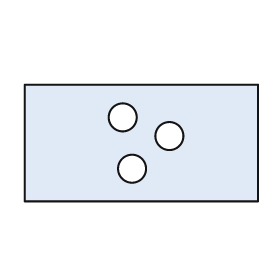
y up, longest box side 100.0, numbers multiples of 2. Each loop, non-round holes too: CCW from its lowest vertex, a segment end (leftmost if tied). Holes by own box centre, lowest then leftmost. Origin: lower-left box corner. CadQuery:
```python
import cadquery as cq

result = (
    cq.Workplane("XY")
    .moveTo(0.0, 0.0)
    .lineTo(100.0, 0.0)
    .lineTo(100.0, 50.0)
    .lineTo(0.0, 50.0)
    .close()
    .moveTo(46.0, 14.0)
    .circle(6.0)
    .moveTo(62.0, 28.0)
    .circle(6.0)
    .moveTo(42.0, 36.0)
    .circle(6.0)
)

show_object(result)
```